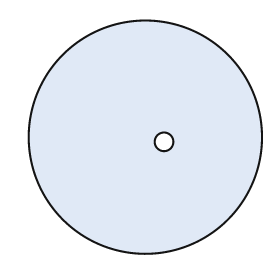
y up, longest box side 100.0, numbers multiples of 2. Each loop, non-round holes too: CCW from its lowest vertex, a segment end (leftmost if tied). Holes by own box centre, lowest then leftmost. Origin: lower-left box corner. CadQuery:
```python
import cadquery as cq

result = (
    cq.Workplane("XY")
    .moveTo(50.0, 50.0)
    .circle(50.0)
    .moveTo(58.0, 48.0)
    .circle(4.0)
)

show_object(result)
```